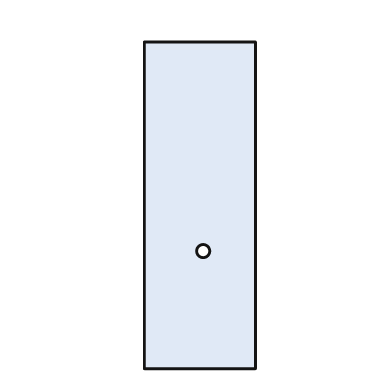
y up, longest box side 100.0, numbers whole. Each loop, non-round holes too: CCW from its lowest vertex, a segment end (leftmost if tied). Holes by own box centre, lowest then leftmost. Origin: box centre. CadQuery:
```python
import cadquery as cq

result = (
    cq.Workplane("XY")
    .moveTo(-17.0, -50.0)
    .lineTo(17.0, -50.0)
    .lineTo(17.0, 50.0)
    .lineTo(-17.0, 50.0)
    .close()
    .moveTo(1.0, -14.0)
    .circle(2.0)
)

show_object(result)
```